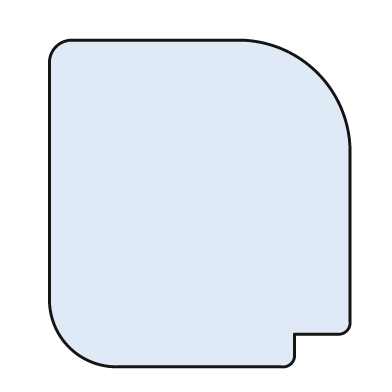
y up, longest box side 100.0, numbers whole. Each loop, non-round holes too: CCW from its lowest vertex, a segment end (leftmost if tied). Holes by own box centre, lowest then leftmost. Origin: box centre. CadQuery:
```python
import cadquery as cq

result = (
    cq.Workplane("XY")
    .moveTo(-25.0, -50.0)
    .lineTo(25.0, -50.0)
    .threePointArc((28.0, -49.0), (29.0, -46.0))
    .lineTo(29.0, -40.0)
    .lineTo(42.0, -40.0)
    .threePointArc((45.0, -39.0), (46.0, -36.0))
    .lineTo(46.0, 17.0)
    .threePointArc((36.0, 40.0), (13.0, 50.0))
    .lineTo(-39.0, 50.0)
    .threePointArc((-44.0, 48.0), (-46.0, 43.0))
    .lineTo(-46.0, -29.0)
    .threePointArc((-40.0, -44.0), (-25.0, -50.0))
    .close()
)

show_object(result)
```